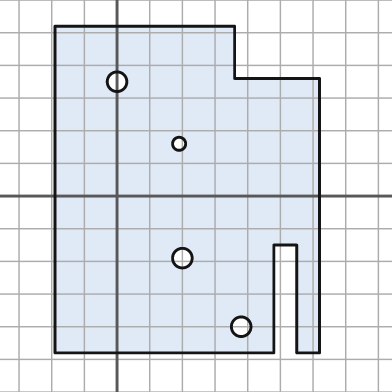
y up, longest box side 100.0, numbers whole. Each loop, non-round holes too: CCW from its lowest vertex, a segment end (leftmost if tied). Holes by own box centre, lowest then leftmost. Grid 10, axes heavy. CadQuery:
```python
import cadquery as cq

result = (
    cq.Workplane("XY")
    .moveTo(-19.0, -48.0)
    .lineTo(48.0, -48.0)
    .lineTo(48.0, -15.0)
    .lineTo(55.0, -15.0)
    .lineTo(55.0, -48.0)
    .lineTo(62.0, -48.0)
    .lineTo(62.0, 36.0)
    .lineTo(36.0, 36.0)
    .lineTo(36.0, 52.0)
    .lineTo(-19.0, 52.0)
    .close()
    .moveTo(38.0, -40.0)
    .circle(3.0)
    .moveTo(20.0, -19.0)
    .circle(3.0)
    .moveTo(19.0, 16.0)
    .circle(2.0)
    .moveTo(0.0, 35.0)
    .circle(3.0)
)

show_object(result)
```